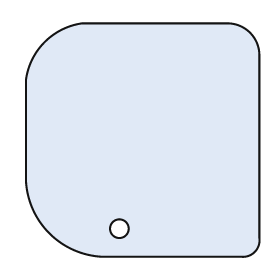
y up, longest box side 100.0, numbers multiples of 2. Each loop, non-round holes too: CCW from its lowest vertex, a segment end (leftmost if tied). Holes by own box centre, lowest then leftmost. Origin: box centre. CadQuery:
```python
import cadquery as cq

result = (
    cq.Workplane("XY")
    .moveTo(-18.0, -50.0)
    .lineTo(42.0, -50.0)
    .threePointArc((48.0, -48.0), (50.0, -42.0))
    .lineTo(50.0, 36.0)
    .threePointArc((46.0, 46.0), (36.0, 50.0))
    .lineTo(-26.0, 50.0)
    .threePointArc((-42.0, 42.0), (-50.0, 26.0))
    .lineTo(-50.0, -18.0)
    .threePointArc((-40.0, -40.0), (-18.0, -50.0))
    .close()
    .moveTo(-10.0, -38.0)
    .circle(4.0)
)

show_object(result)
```